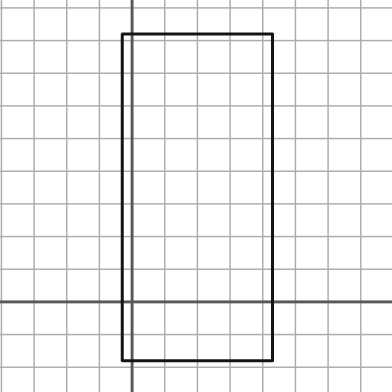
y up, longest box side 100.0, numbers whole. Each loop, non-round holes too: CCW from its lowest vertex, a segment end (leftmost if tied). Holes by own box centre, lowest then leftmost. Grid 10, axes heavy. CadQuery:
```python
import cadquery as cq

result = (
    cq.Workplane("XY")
    .moveTo(-3.0, -18.0)
    .lineTo(43.0, -18.0)
    .lineTo(43.0, 82.0)
    .lineTo(-3.0, 82.0)
    .close()
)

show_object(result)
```